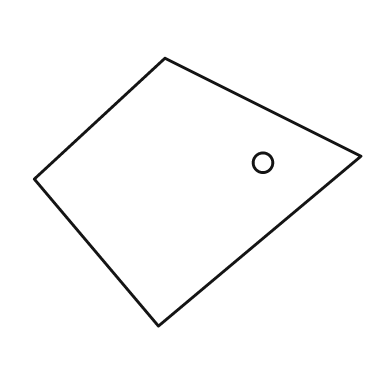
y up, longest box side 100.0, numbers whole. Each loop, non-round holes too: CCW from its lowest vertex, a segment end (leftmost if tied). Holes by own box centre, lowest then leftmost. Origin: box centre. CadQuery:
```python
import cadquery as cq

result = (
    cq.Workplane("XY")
    .moveTo(-12.0, -41.0)
    .lineTo(50.0, 11.0)
    .lineTo(-10.0, 41.0)
    .lineTo(-50.0, 4.0)
    .close()
    .moveTo(20.0, 9.0)
    .circle(3.0)
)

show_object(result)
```